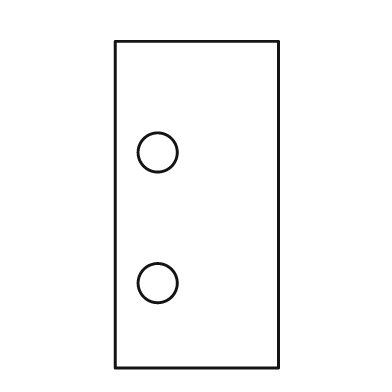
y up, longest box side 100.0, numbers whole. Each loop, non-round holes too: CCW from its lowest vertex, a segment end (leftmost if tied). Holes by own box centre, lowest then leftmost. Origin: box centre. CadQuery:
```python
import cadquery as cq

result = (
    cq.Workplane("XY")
    .moveTo(-25.0, -50.0)
    .lineTo(25.0, -50.0)
    .lineTo(25.0, 50.0)
    .lineTo(-25.0, 50.0)
    .close()
    .moveTo(-12.0, -24.0)
    .circle(6.0)
    .moveTo(-12.0, 16.0)
    .circle(6.0)
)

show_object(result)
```